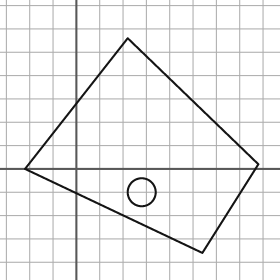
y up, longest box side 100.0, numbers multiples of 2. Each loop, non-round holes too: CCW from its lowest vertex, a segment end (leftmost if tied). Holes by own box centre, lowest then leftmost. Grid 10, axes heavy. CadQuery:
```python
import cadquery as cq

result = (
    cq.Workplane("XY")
    .moveTo(54.0, -36.0)
    .lineTo(78.0, 2.0)
    .lineTo(22.0, 56.0)
    .lineTo(-22.0, 0.0)
    .close()
    .moveTo(28.0, -10.0)
    .circle(6.0)
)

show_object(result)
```